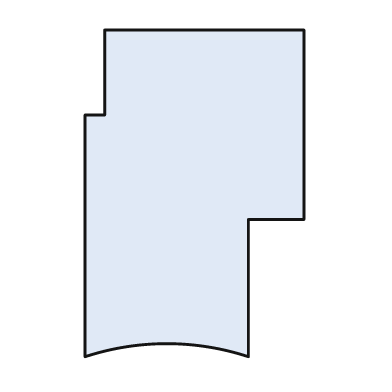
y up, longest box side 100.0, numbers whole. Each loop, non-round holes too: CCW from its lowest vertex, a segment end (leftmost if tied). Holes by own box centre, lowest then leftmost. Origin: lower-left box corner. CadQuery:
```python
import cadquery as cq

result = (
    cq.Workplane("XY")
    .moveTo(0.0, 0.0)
    .threePointArc((25.0, 4.0), (50.0, 0.0))
    .lineTo(50.0, 42.0)
    .lineTo(67.0, 42.0)
    .lineTo(67.0, 100.0)
    .lineTo(6.0, 100.0)
    .lineTo(6.0, 74.0)
    .lineTo(0.0, 74.0)
    .close()
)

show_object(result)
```